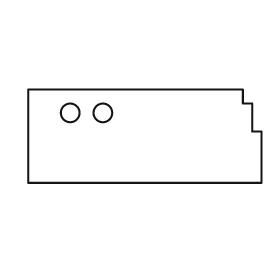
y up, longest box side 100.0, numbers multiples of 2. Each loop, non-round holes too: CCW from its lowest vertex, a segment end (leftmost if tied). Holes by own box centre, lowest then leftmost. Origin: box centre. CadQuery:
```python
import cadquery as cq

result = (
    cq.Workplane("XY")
    .moveTo(-50.0, -20.0)
    .lineTo(50.0, -20.0)
    .lineTo(50.0, 2.0)
    .lineTo(46.0, 2.0)
    .lineTo(46.0, 14.0)
    .lineTo(42.0, 14.0)
    .lineTo(42.0, 20.0)
    .lineTo(-50.0, 20.0)
    .close()
    .moveTo(-32.0, 10.0)
    .circle(4.0)
    .moveTo(-18.0, 10.0)
    .circle(4.0)
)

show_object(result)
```